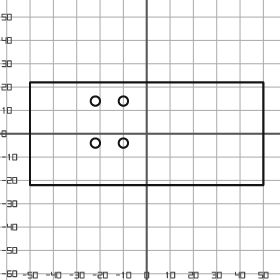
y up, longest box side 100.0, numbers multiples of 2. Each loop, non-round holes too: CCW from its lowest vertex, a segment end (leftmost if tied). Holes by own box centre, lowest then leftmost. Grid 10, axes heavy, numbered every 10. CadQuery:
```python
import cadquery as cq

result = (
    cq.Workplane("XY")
    .moveTo(-50.0, -22.0)
    .lineTo(50.0, -22.0)
    .lineTo(50.0, 22.0)
    .lineTo(-50.0, 22.0)
    .close()
    .moveTo(-22.0, -4.0)
    .circle(2.0)
    .moveTo(-10.0, -4.0)
    .circle(2.0)
    .moveTo(-22.0, 14.0)
    .circle(2.0)
    .moveTo(-10.0, 14.0)
    .circle(2.0)
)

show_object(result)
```